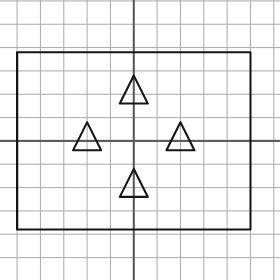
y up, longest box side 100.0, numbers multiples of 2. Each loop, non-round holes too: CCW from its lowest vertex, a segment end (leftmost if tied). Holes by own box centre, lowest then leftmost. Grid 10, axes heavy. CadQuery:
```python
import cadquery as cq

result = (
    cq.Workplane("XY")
    .moveTo(-50.0, -38.0)
    .lineTo(50.0, -38.0)
    .lineTo(50.0, 38.0)
    .lineTo(-50.0, 38.0)
    .close()
    .moveTo(-6.0, -24.0)
    .lineTo(6.0, -24.0)
    .lineTo(0.0, -12.0)
    .close()
    .moveTo(-26.0, -4.0)
    .lineTo(-14.0, -4.0)
    .lineTo(-20.0, 8.0)
    .close()
    .moveTo(14.0, -4.0)
    .lineTo(26.0, -4.0)
    .lineTo(20.0, 8.0)
    .close()
    .moveTo(-6.0, 16.0)
    .lineTo(6.0, 16.0)
    .lineTo(0.0, 28.0)
    .close()
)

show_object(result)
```